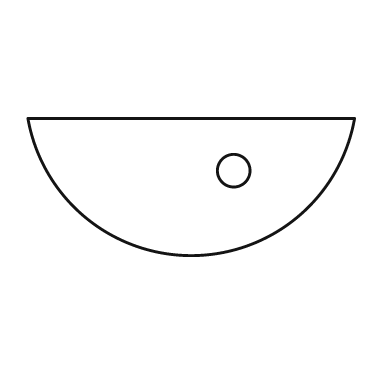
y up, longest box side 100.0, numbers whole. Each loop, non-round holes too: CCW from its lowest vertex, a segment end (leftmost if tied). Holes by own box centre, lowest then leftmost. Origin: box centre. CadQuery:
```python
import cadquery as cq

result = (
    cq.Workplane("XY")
    .moveTo(-50.0, 21.0)
    .threePointArc((0.0, -21.0), (50.0, 21.0))
    .close()
    .moveTo(13.0, 5.0)
    .circle(5.0)
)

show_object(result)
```